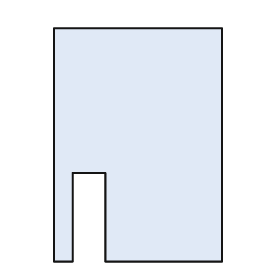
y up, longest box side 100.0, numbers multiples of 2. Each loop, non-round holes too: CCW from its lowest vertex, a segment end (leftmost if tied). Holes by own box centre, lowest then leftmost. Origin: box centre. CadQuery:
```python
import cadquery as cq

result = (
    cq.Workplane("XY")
    .moveTo(-36.0, -50.0)
    .lineTo(-28.0, -50.0)
    .lineTo(-28.0, -12.0)
    .lineTo(-14.0, -12.0)
    .lineTo(-14.0, -50.0)
    .lineTo(36.0, -50.0)
    .lineTo(36.0, 50.0)
    .lineTo(-36.0, 50.0)
    .close()
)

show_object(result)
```